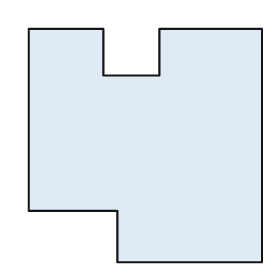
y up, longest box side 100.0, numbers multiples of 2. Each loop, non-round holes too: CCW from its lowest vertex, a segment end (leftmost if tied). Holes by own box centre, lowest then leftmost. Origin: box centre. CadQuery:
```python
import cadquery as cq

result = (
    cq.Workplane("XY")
    .moveTo(-12.0, -50.0)
    .lineTo(50.0, -50.0)
    .lineTo(50.0, 50.0)
    .lineTo(6.0, 50.0)
    .lineTo(6.0, 30.0)
    .lineTo(-18.0, 30.0)
    .lineTo(-18.0, 50.0)
    .lineTo(-50.0, 50.0)
    .lineTo(-50.0, -28.0)
    .lineTo(-12.0, -28.0)
    .close()
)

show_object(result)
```